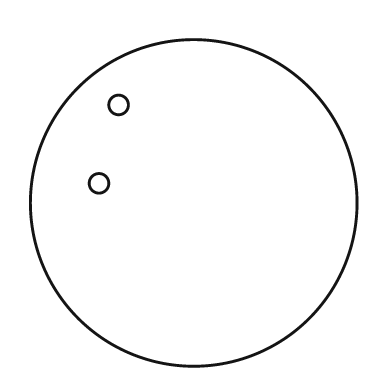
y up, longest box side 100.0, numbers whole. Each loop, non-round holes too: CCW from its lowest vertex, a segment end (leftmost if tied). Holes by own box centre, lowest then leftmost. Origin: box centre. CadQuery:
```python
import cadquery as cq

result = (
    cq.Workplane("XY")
    .moveTo(0.0, 0.0)
    .circle(50.0)
    .moveTo(-29.0, 6.0)
    .circle(3.0)
    .moveTo(-23.0, 30.0)
    .circle(3.0)
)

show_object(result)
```